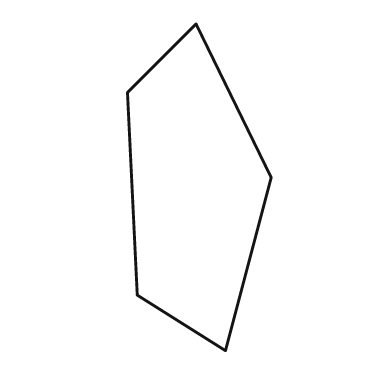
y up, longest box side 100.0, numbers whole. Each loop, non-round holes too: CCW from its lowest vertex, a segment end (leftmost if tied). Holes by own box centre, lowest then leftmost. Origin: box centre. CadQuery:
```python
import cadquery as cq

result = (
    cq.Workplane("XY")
    .moveTo(8.0, -50.0)
    .lineTo(22.0, 3.0)
    .lineTo(-1.0, 50.0)
    .lineTo(-22.0, 29.0)
    .lineTo(-19.0, -33.0)
    .close()
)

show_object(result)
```